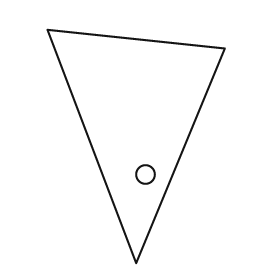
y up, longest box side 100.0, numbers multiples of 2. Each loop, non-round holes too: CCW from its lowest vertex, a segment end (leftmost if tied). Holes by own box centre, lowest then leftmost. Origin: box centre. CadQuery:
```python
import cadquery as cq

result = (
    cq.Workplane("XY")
    .moveTo(0.0, -50.0)
    .lineTo(38.0, 42.0)
    .lineTo(-38.0, 50.0)
    .close()
    .moveTo(4.0, -12.0)
    .circle(4.0)
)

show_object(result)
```